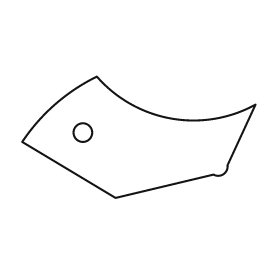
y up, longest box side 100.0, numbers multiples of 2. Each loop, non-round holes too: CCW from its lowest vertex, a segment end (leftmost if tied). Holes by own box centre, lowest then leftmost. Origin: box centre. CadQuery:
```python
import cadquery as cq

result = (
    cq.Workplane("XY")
    .moveTo(-10.0, -26.0)
    .lineTo(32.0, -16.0)
    .threePointArc((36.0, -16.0), (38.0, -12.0))
    .lineTo(50.0, 14.0)
    .threePointArc((14.0, 8.0), (-18.0, 26.0))
    .threePointArc((-36.0, 14.0), (-50.0, -2.0))
    .close()
    .moveTo(-24.0, 2.0)
    .circle(4.0)
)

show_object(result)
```